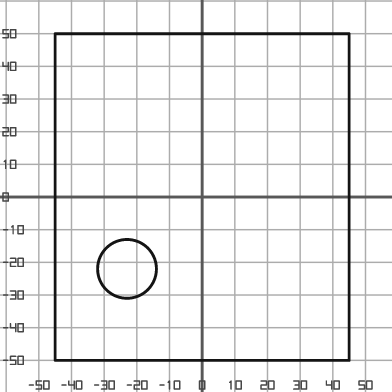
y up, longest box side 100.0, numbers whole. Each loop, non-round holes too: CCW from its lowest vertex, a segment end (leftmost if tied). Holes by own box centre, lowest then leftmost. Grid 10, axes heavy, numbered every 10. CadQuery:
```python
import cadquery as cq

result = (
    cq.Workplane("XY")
    .moveTo(-45.0, -50.0)
    .lineTo(45.0, -50.0)
    .lineTo(45.0, 50.0)
    .lineTo(-45.0, 50.0)
    .close()
    .moveTo(-23.0, -22.0)
    .circle(9.0)
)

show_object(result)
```